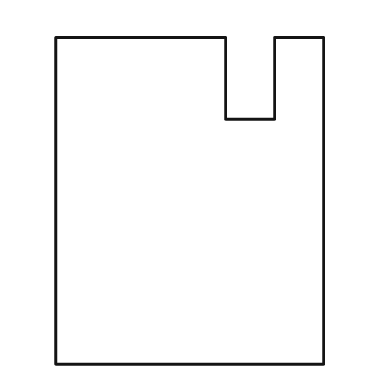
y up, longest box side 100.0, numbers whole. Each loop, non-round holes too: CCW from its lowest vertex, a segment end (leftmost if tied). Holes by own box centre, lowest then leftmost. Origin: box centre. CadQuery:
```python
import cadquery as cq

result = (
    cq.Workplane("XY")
    .moveTo(-41.0, -50.0)
    .lineTo(41.0, -50.0)
    .lineTo(41.0, 50.0)
    .lineTo(26.0, 50.0)
    .lineTo(26.0, 25.0)
    .lineTo(11.0, 25.0)
    .lineTo(11.0, 50.0)
    .lineTo(-41.0, 50.0)
    .close()
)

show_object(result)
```